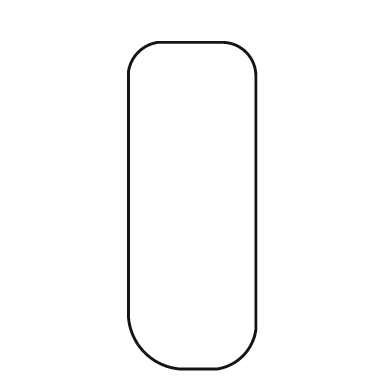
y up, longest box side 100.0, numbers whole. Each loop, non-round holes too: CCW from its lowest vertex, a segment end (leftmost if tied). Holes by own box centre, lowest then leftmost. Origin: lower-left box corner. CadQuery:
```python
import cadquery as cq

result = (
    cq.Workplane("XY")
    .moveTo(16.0, 0.0)
    .lineTo(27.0, 0.0)
    .threePointArc((35.0, 4.0), (39.0, 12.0))
    .lineTo(39.0, 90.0)
    .threePointArc((36.0, 97.0), (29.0, 100.0))
    .lineTo(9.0, 100.0)
    .threePointArc((3.0, 97.0), (0.0, 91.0))
    .lineTo(0.0, 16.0)
    .threePointArc((5.0, 5.0), (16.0, 0.0))
    .close()
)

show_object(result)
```